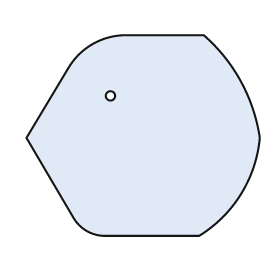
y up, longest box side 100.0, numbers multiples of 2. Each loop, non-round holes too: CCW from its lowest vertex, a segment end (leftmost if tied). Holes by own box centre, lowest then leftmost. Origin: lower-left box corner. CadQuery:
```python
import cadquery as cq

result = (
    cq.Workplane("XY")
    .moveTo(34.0, 0.0)
    .lineTo(74.0, 0.0)
    .threePointArc((92.0, 18.0), (100.0, 42.0))
    .threePointArc((92.0, 66.0), (76.0, 86.0))
    .lineTo(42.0, 86.0)
    .threePointArc((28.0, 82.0), (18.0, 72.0))
    .lineTo(0.0, 42.0)
    .lineTo(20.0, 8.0)
    .threePointArc((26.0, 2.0), (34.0, 0.0))
    .close()
    .moveTo(36.0, 60.0)
    .circle(2.0)
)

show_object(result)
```